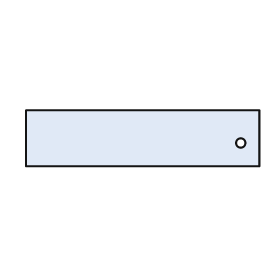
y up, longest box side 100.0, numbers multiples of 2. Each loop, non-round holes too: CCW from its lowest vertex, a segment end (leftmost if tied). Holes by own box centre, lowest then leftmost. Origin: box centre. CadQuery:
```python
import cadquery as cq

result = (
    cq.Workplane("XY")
    .moveTo(-50.0, -12.0)
    .lineTo(50.0, -12.0)
    .lineTo(50.0, 12.0)
    .lineTo(-50.0, 12.0)
    .close()
    .moveTo(42.0, -2.0)
    .circle(2.0)
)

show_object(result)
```